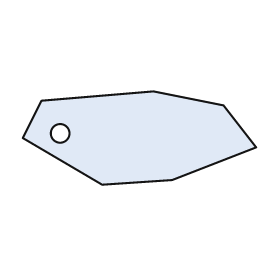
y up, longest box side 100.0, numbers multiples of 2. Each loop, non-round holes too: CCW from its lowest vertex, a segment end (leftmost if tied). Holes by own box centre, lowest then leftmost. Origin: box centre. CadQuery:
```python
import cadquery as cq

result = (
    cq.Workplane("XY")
    .moveTo(-16.0, -20.0)
    .lineTo(14.0, -18.0)
    .lineTo(50.0, -4.0)
    .lineTo(36.0, 14.0)
    .lineTo(6.0, 20.0)
    .lineTo(-42.0, 16.0)
    .lineTo(-50.0, 0.0)
    .close()
    .moveTo(-34.0, 2.0)
    .circle(4.0)
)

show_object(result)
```